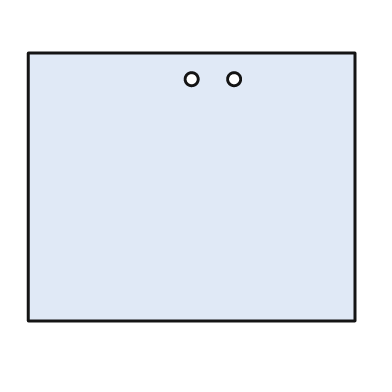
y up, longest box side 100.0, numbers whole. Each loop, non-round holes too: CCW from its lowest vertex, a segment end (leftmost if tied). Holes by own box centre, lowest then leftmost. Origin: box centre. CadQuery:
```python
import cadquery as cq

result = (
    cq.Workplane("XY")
    .moveTo(-50.0, -41.0)
    .lineTo(50.0, -41.0)
    .lineTo(50.0, 41.0)
    .lineTo(-50.0, 41.0)
    .close()
    .moveTo(0.0, 33.0)
    .circle(2.0)
    .moveTo(13.0, 33.0)
    .circle(2.0)
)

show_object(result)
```